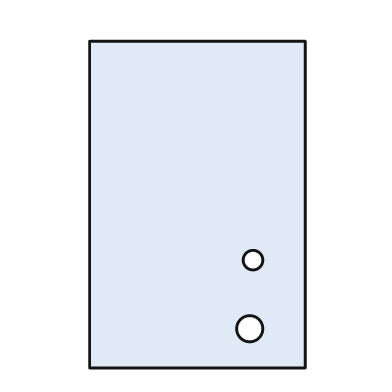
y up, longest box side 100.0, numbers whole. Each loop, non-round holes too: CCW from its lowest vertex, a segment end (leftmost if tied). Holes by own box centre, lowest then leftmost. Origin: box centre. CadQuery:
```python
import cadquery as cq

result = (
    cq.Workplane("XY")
    .moveTo(-33.0, -50.0)
    .lineTo(33.0, -50.0)
    .lineTo(33.0, 50.0)
    .lineTo(-33.0, 50.0)
    .close()
    .moveTo(16.0, -38.0)
    .circle(4.0)
    .moveTo(17.0, -17.0)
    .circle(3.0)
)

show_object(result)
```